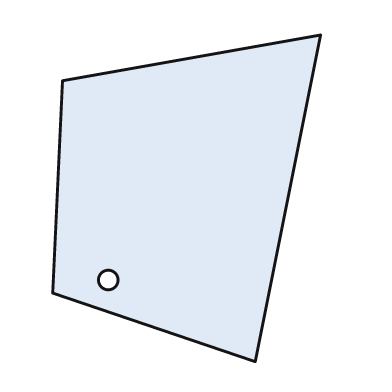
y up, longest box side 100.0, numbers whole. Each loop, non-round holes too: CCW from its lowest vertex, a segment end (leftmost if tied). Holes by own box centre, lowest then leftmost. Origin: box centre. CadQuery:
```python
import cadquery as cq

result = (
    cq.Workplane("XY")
    .moveTo(21.0, -50.0)
    .lineTo(41.0, 50.0)
    .lineTo(-38.0, 36.0)
    .lineTo(-41.0, -29.0)
    .close()
    .moveTo(-24.0, -25.0)
    .circle(3.0)
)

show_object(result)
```